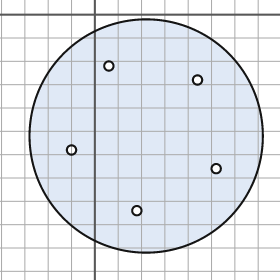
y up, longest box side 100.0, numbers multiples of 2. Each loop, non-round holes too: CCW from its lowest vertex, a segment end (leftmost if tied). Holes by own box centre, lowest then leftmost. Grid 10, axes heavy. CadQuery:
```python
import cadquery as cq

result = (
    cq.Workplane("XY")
    .moveTo(22.0, -52.0)
    .circle(50.0)
    .moveTo(18.0, -84.0)
    .circle(2.0)
    .moveTo(52.0, -66.0)
    .circle(2.0)
    .moveTo(-10.0, -58.0)
    .circle(2.0)
    .moveTo(44.0, -28.0)
    .circle(2.0)
    .moveTo(6.0, -22.0)
    .circle(2.0)
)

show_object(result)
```